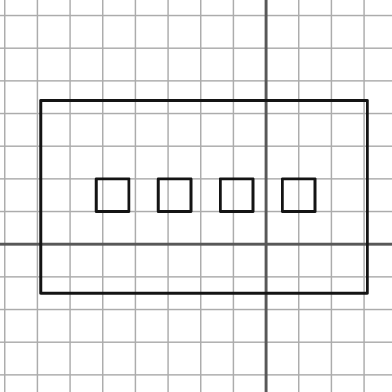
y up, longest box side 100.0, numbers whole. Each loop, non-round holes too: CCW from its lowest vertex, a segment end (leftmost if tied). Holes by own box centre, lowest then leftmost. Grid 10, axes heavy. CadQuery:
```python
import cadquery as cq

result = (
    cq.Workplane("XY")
    .moveTo(-69.0, -15.0)
    .lineTo(31.0, -15.0)
    .lineTo(31.0, 44.0)
    .lineTo(-69.0, 44.0)
    .close()
    .moveTo(-52.0, 10.0)
    .lineTo(-42.0, 10.0)
    .lineTo(-42.0, 20.0)
    .lineTo(-52.0, 20.0)
    .close()
    .moveTo(-33.0, 10.0)
    .lineTo(-23.0, 10.0)
    .lineTo(-23.0, 20.0)
    .lineTo(-33.0, 20.0)
    .close()
    .moveTo(-14.0, 10.0)
    .lineTo(-4.0, 10.0)
    .lineTo(-4.0, 20.0)
    .lineTo(-14.0, 20.0)
    .close()
    .moveTo(5.0, 10.0)
    .lineTo(15.0, 10.0)
    .lineTo(15.0, 20.0)
    .lineTo(5.0, 20.0)
    .close()
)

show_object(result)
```